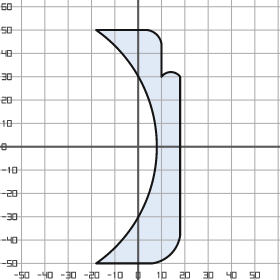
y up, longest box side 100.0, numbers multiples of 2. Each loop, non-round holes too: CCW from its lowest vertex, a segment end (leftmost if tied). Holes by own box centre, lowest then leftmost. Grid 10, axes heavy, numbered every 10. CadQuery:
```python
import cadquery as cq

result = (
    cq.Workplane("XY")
    .moveTo(-18.0, -50.0)
    .lineTo(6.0, -50.0)
    .threePointArc((14.0, -46.0), (18.0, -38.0))
    .lineTo(18.0, 30.0)
    .threePointArc((14.0, 32.0), (10.0, 30.0))
    .lineTo(10.0, 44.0)
    .threePointArc((8.0, 48.0), (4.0, 50.0))
    .lineTo(-18.0, 50.0)
    .threePointArc((8.0, 0.0), (-18.0, -50.0))
    .close()
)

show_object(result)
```